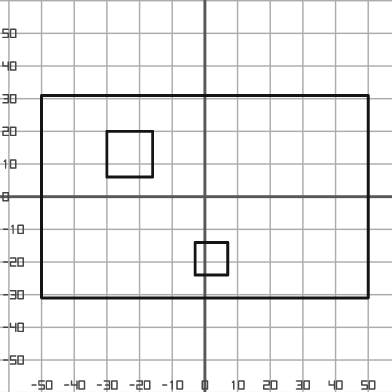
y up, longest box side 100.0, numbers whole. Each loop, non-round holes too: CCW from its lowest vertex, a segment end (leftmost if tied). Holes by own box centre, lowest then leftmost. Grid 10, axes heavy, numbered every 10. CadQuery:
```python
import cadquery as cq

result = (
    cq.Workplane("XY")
    .moveTo(-50.0, -31.0)
    .lineTo(50.0, -31.0)
    .lineTo(50.0, 31.0)
    .lineTo(-50.0, 31.0)
    .close()
    .moveTo(-3.0, -24.0)
    .lineTo(7.0, -24.0)
    .lineTo(7.0, -14.0)
    .lineTo(-3.0, -14.0)
    .close()
    .moveTo(-30.0, 6.0)
    .lineTo(-16.0, 6.0)
    .lineTo(-16.0, 20.0)
    .lineTo(-30.0, 20.0)
    .close()
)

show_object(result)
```